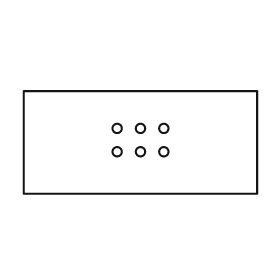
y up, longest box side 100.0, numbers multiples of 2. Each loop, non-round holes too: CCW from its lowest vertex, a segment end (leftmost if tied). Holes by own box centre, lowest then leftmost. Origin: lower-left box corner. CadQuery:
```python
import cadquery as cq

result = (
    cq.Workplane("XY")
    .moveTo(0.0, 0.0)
    .lineTo(100.0, 0.0)
    .lineTo(100.0, 44.0)
    .lineTo(0.0, 44.0)
    .close()
    .moveTo(40.0, 18.0)
    .circle(2.0)
    .moveTo(50.0, 18.0)
    .circle(2.0)
    .moveTo(60.0, 18.0)
    .circle(2.0)
    .moveTo(40.0, 28.0)
    .circle(2.0)
    .moveTo(50.0, 28.0)
    .circle(2.0)
    .moveTo(60.0, 28.0)
    .circle(2.0)
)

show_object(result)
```